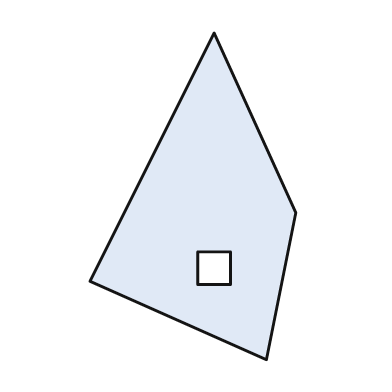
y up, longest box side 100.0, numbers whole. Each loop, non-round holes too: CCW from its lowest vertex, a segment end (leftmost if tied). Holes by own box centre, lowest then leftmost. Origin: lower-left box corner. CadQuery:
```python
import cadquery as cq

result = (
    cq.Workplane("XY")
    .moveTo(54.0, 0.0)
    .lineTo(63.0, 45.0)
    .lineTo(38.0, 100.0)
    .lineTo(0.0, 24.0)
    .close()
    .moveTo(33.0, 23.0)
    .lineTo(43.0, 23.0)
    .lineTo(43.0, 33.0)
    .lineTo(33.0, 33.0)
    .close()
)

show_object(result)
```